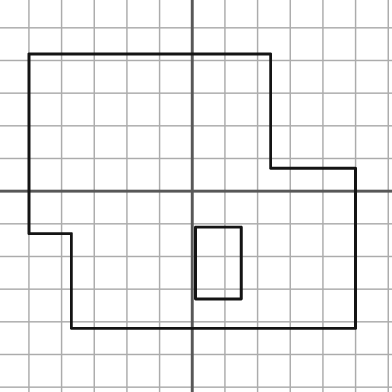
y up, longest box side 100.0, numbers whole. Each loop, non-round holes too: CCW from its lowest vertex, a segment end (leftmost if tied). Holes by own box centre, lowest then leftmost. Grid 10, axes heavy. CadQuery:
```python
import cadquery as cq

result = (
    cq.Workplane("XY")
    .moveTo(-37.0, -42.0)
    .lineTo(50.0, -42.0)
    .lineTo(50.0, 7.0)
    .lineTo(24.0, 7.0)
    .lineTo(24.0, 42.0)
    .lineTo(-50.0, 42.0)
    .lineTo(-50.0, -13.0)
    .lineTo(-37.0, -13.0)
    .close()
    .moveTo(1.0, -33.0)
    .lineTo(15.0, -33.0)
    .lineTo(15.0, -11.0)
    .lineTo(1.0, -11.0)
    .close()
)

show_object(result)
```